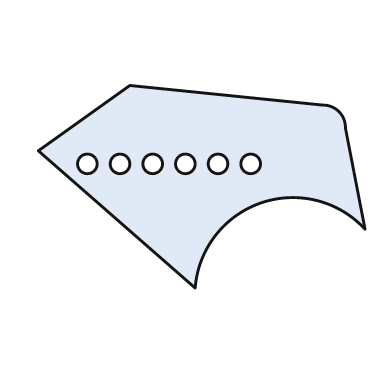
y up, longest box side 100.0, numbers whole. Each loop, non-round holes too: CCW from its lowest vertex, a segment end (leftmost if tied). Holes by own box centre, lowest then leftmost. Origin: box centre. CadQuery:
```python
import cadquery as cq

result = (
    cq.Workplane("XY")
    .moveTo(-2.0, -31.0)
    .threePointArc((18.0, -5.0), (50.0, -13.0))
    .lineTo(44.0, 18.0)
    .threePointArc((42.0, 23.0), (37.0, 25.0))
    .lineTo(-22.0, 31.0)
    .lineTo(-50.0, 11.0)
    .close()
    .moveTo(-35.0, 7.0)
    .circle(3.0)
    .moveTo(-25.0, 7.0)
    .circle(3.0)
    .moveTo(-15.0, 7.0)
    .circle(3.0)
    .moveTo(-5.0, 7.0)
    .circle(3.0)
    .moveTo(5.0, 7.0)
    .circle(3.0)
    .moveTo(15.0, 7.0)
    .circle(3.0)
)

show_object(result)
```